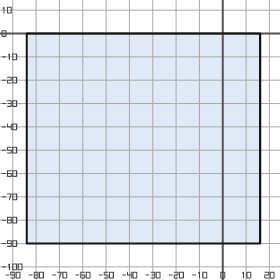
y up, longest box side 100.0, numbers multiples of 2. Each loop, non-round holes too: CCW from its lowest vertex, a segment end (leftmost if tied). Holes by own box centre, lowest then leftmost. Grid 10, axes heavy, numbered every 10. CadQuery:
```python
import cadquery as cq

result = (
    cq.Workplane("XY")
    .moveTo(-84.0, -90.0)
    .lineTo(16.0, -90.0)
    .lineTo(16.0, 0.0)
    .lineTo(-84.0, 0.0)
    .close()
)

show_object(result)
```